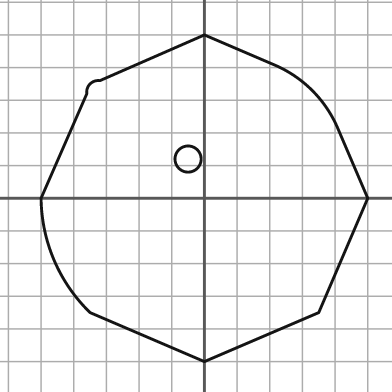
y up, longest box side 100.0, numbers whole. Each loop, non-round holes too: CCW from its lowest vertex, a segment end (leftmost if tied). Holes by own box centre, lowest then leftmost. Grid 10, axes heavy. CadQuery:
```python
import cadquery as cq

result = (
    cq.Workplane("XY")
    .moveTo(0.0, -50.0)
    .lineTo(35.0, -35.0)
    .lineTo(50.0, 0.0)
    .lineTo(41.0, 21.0)
    .threePointArc((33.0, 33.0), (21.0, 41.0))
    .lineTo(0.0, 50.0)
    .lineTo(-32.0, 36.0)
    .threePointArc((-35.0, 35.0), (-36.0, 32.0))
    .lineTo(-50.0, 0.0)
    .threePointArc((-46.0, -19.0), (-35.0, -35.0))
    .close()
    .moveTo(-5.0, 12.0)
    .circle(4.0)
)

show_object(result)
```